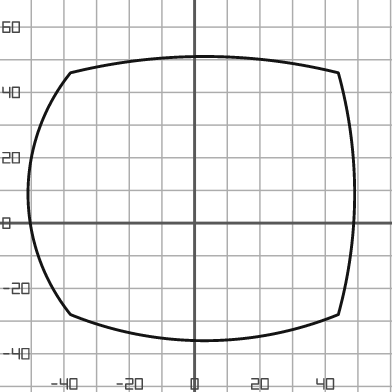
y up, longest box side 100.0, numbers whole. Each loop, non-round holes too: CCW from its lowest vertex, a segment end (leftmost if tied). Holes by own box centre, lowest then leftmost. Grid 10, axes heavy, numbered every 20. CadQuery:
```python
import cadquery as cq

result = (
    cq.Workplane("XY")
    .moveTo(-38.0, -28.0)
    .threePointArc((3.0, -36.0), (44.0, -28.0))
    .threePointArc((49.0, 9.0), (44.0, 46.0))
    .threePointArc((3.0, 51.0), (-38.0, 46.0))
    .threePointArc((-51.0, 9.0), (-38.0, -28.0))
    .close()
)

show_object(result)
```